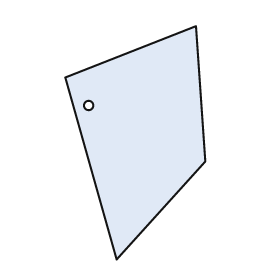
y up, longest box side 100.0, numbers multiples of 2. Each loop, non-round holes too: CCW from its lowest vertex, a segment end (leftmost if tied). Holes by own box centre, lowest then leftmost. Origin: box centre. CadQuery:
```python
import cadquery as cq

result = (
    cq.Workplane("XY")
    .moveTo(-8.0, -50.0)
    .lineTo(30.0, -8.0)
    .lineTo(26.0, 50.0)
    .lineTo(-30.0, 28.0)
    .close()
    .moveTo(-20.0, 16.0)
    .circle(2.0)
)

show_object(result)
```